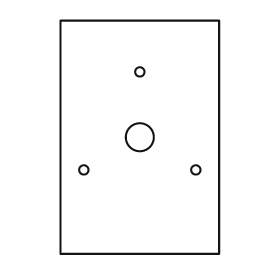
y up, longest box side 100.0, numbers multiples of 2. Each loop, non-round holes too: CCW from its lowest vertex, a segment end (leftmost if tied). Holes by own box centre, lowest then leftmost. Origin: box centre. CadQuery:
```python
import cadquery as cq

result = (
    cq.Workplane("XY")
    .moveTo(-34.0, -50.0)
    .lineTo(34.0, -50.0)
    .lineTo(34.0, 50.0)
    .lineTo(-34.0, 50.0)
    .close()
    .moveTo(-24.0, -14.0)
    .circle(2.0)
    .moveTo(24.0, -14.0)
    .circle(2.0)
    .moveTo(0.0, 0.0)
    .circle(6.0)
    .moveTo(0.0, 28.0)
    .circle(2.0)
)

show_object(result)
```